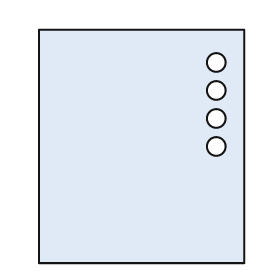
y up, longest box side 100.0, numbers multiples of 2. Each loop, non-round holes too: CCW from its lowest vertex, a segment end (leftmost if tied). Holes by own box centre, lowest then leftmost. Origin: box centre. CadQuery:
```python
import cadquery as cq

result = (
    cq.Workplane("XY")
    .moveTo(-44.0, -50.0)
    .lineTo(44.0, -50.0)
    .lineTo(44.0, 50.0)
    .lineTo(-44.0, 50.0)
    .close()
    .moveTo(32.0, 0.0)
    .circle(4.0)
    .moveTo(32.0, 12.0)
    .circle(4.0)
    .moveTo(32.0, 24.0)
    .circle(4.0)
    .moveTo(32.0, 36.0)
    .circle(4.0)
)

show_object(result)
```